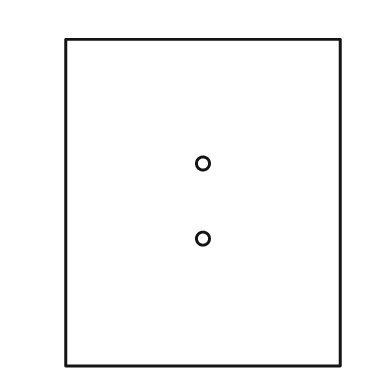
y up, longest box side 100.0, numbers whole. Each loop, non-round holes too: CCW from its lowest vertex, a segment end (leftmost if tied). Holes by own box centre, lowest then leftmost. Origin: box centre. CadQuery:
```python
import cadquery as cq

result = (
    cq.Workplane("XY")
    .moveTo(-42.0, -50.0)
    .lineTo(42.0, -50.0)
    .lineTo(42.0, 50.0)
    .lineTo(-42.0, 50.0)
    .close()
    .moveTo(0.0, -11.0)
    .circle(2.0)
    .moveTo(0.0, 12.0)
    .circle(2.0)
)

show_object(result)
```